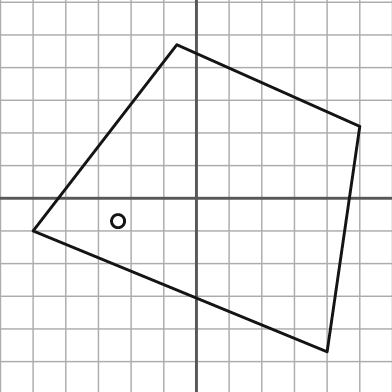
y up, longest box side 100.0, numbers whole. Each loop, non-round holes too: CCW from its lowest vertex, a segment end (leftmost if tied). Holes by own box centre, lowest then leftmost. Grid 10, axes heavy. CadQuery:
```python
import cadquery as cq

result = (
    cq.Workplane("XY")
    .moveTo(40.0, -47.0)
    .lineTo(50.0, 22.0)
    .lineTo(-6.0, 47.0)
    .lineTo(-50.0, -10.0)
    .close()
    .moveTo(-24.0, -7.0)
    .circle(2.0)
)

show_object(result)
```